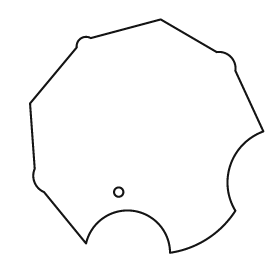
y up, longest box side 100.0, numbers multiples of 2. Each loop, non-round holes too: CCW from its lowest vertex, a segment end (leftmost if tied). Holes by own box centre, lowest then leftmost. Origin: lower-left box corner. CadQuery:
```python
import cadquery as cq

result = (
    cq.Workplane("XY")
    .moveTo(60.0, 0.0)
    .threePointArc((76.0, 6.0), (88.0, 18.0))
    .threePointArc((86.0, 38.0), (100.0, 52.0))
    .lineTo(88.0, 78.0)
    .threePointArc((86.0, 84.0), (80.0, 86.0))
    .lineTo(56.0, 100.0)
    .lineTo(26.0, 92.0)
    .threePointArc((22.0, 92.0), (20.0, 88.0))
    .lineTo(0.0, 64.0)
    .lineTo(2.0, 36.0)
    .threePointArc((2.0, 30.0), (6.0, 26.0))
    .lineTo(24.0, 4.0)
    .threePointArc((44.0, 18.0), (60.0, 0.0))
    .close()
    .moveTo(38.0, 26.0)
    .circle(2.0)
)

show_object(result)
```